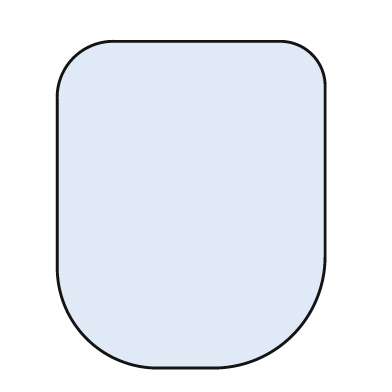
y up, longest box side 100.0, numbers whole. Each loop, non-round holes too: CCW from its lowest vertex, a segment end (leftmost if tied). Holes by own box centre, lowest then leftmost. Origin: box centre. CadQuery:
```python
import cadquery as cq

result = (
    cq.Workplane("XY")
    .moveTo(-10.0, -50.0)
    .lineTo(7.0, -50.0)
    .threePointArc((31.0, -40.0), (41.0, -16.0))
    .lineTo(41.0, 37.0)
    .threePointArc((37.0, 46.0), (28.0, 50.0))
    .lineTo(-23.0, 50.0)
    .threePointArc((-36.0, 45.0), (-41.0, 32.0))
    .lineTo(-41.0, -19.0)
    .threePointArc((-32.0, -41.0), (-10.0, -50.0))
    .close()
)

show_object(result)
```